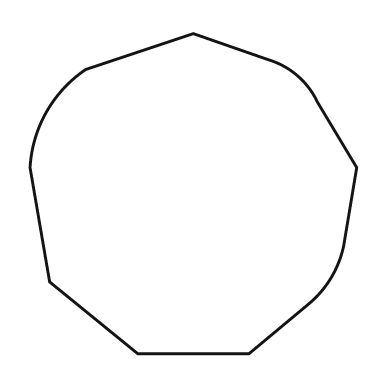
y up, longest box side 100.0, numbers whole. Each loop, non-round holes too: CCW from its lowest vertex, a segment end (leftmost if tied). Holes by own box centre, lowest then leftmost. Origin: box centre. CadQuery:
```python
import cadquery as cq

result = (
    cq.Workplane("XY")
    .moveTo(-17.0, -49.0)
    .lineTo(17.0, -49.0)
    .lineTo(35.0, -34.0)
    .threePointArc((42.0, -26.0), (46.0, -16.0))
    .lineTo(50.0, 8.0)
    .lineTo(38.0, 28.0)
    .threePointArc((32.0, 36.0), (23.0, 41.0))
    .lineTo(0.0, 49.0)
    .lineTo(-33.0, 38.0)
    .threePointArc((-45.0, 25.0), (-50.0, 8.0))
    .lineTo(-44.0, -27.0)
    .close()
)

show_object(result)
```